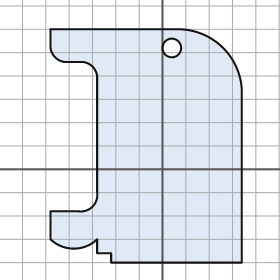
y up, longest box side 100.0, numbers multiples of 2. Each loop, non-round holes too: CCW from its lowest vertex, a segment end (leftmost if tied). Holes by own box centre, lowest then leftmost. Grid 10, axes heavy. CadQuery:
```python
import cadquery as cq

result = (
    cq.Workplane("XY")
    .moveTo(-22.0, -40.0)
    .lineTo(34.0, -40.0)
    .lineTo(34.0, 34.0)
    .threePointArc((26.0, 52.0), (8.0, 60.0))
    .lineTo(-48.0, 60.0)
    .lineTo(-48.0, 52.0)
    .threePointArc((-46.0, 48.0), (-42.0, 46.0))
    .lineTo(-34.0, 46.0)
    .threePointArc((-30.0, 44.0), (-28.0, 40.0))
    .lineTo(-28.0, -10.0)
    .threePointArc((-30.0, -16.0), (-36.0, -18.0))
    .lineTo(-48.0, -18.0)
    .lineTo(-48.0, -30.0)
    .threePointArc((-38.0, -34.0), (-28.0, -30.0))
    .lineTo(-28.0, -36.0)
    .lineTo(-22.0, -36.0)
    .close()
    .moveTo(4.0, 52.0)
    .circle(4.0)
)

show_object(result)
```